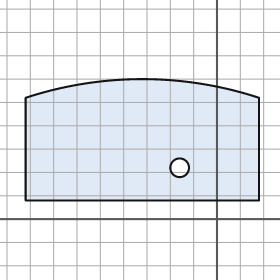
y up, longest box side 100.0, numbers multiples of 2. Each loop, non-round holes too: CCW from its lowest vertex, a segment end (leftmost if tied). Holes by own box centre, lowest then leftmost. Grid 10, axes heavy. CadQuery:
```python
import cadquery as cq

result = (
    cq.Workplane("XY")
    .moveTo(-82.0, 8.0)
    .lineTo(18.0, 8.0)
    .lineTo(18.0, 52.0)
    .threePointArc((-32.0, 60.0), (-82.0, 52.0))
    .close()
    .moveTo(-16.0, 22.0)
    .circle(4.0)
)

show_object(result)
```